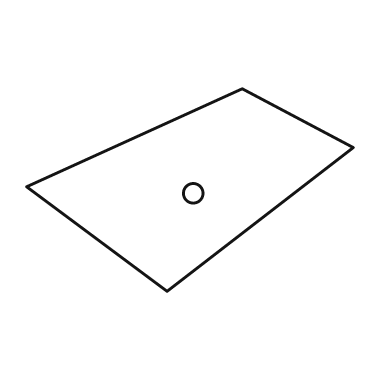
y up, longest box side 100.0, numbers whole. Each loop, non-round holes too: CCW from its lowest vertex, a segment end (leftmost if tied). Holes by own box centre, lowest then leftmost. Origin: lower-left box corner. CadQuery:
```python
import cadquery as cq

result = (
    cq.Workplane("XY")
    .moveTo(43.0, 0.0)
    .lineTo(100.0, 44.0)
    .lineTo(66.0, 62.0)
    .lineTo(0.0, 32.0)
    .close()
    .moveTo(51.0, 30.0)
    .circle(3.0)
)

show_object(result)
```